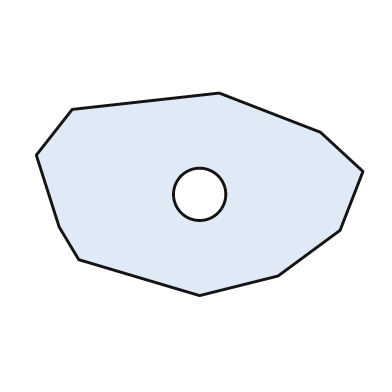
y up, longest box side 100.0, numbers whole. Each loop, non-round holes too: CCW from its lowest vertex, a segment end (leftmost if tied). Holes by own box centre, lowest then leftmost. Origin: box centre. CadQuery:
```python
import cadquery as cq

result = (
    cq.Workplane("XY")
    .moveTo(0.0, -31.0)
    .lineTo(24.0, -25.0)
    .lineTo(43.0, -11.0)
    .lineTo(50.0, 7.0)
    .lineTo(37.0, 19.0)
    .lineTo(6.0, 31.0)
    .lineTo(-39.0, 26.0)
    .lineTo(-50.0, 12.0)
    .lineTo(-43.0, -10.0)
    .lineTo(-37.0, -20.0)
    .close()
    .moveTo(0.0, 0.0)
    .circle(8.0)
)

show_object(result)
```